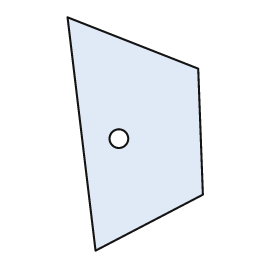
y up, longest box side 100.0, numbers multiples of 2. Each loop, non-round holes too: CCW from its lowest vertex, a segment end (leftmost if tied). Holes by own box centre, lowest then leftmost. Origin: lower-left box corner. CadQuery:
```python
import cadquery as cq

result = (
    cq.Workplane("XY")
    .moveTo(12.0, 0.0)
    .lineTo(58.0, 24.0)
    .lineTo(56.0, 78.0)
    .lineTo(0.0, 100.0)
    .close()
    .moveTo(22.0, 48.0)
    .circle(4.0)
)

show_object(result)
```